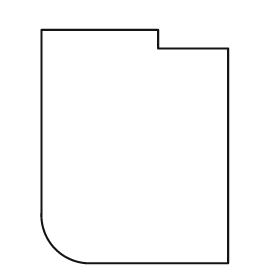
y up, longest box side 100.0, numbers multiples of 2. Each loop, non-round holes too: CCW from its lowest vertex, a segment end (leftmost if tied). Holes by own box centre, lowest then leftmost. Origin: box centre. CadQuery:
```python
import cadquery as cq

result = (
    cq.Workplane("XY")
    .moveTo(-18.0, -50.0)
    .lineTo(40.0, -50.0)
    .lineTo(40.0, 42.0)
    .lineTo(10.0, 42.0)
    .lineTo(10.0, 50.0)
    .lineTo(-40.0, 50.0)
    .lineTo(-40.0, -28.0)
    .threePointArc((-34.0, -44.0), (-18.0, -50.0))
    .close()
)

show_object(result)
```